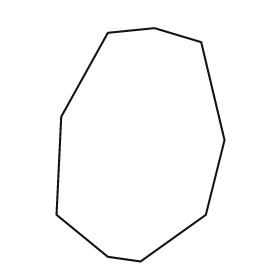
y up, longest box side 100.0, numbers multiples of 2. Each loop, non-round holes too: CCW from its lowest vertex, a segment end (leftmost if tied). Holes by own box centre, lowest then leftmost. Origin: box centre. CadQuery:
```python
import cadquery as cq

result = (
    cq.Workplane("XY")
    .moveTo(0.0, -50.0)
    .lineTo(28.0, -30.0)
    .lineTo(36.0, 2.0)
    .lineTo(26.0, 44.0)
    .lineTo(6.0, 50.0)
    .lineTo(-14.0, 48.0)
    .lineTo(-34.0, 12.0)
    .lineTo(-36.0, -30.0)
    .lineTo(-14.0, -48.0)
    .close()
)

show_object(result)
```